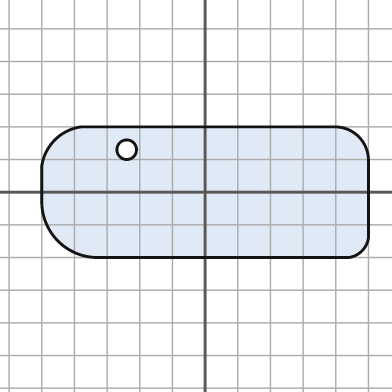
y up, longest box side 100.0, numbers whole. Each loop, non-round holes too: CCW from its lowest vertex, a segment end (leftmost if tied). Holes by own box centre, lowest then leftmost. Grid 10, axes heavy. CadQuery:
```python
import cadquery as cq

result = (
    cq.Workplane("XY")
    .moveTo(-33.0, -20.0)
    .lineTo(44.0, -20.0)
    .threePointArc((48.0, -18.0), (50.0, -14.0))
    .lineTo(50.0, 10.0)
    .threePointArc((47.0, 17.0), (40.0, 20.0))
    .lineTo(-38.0, 20.0)
    .threePointArc((-46.0, 16.0), (-50.0, 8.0))
    .lineTo(-50.0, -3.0)
    .threePointArc((-45.0, -15.0), (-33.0, -20.0))
    .close()
    .moveTo(-24.0, 13.0)
    .circle(3.0)
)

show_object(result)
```